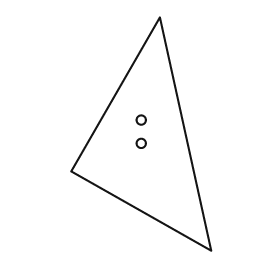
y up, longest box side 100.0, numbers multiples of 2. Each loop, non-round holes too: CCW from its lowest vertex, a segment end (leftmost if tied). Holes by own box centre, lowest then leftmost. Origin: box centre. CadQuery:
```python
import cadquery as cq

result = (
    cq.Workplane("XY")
    .moveTo(30.0, -50.0)
    .lineTo(8.0, 50.0)
    .lineTo(-30.0, -16.0)
    .close()
    .moveTo(0.0, -4.0)
    .circle(2.0)
    .moveTo(0.0, 6.0)
    .circle(2.0)
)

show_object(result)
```